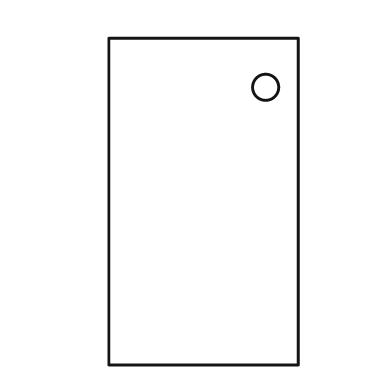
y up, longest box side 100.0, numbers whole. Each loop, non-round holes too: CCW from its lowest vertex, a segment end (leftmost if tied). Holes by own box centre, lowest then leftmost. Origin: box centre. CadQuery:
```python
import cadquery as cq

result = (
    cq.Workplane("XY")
    .moveTo(-29.0, -50.0)
    .lineTo(29.0, -50.0)
    .lineTo(29.0, 50.0)
    .lineTo(-29.0, 50.0)
    .close()
    .moveTo(19.0, 35.0)
    .circle(4.0)
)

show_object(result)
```